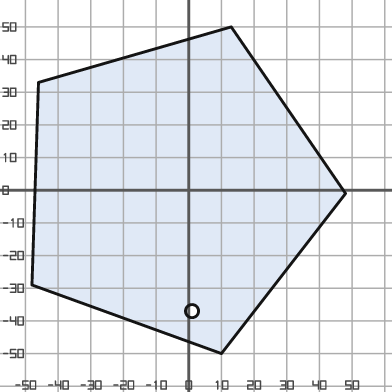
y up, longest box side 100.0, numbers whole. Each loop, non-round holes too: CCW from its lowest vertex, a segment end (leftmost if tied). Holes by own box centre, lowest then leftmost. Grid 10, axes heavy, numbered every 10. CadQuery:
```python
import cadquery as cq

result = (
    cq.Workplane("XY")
    .moveTo(10.0, -50.0)
    .lineTo(48.0, -1.0)
    .lineTo(13.0, 50.0)
    .lineTo(-46.0, 33.0)
    .lineTo(-48.0, -29.0)
    .close()
    .moveTo(1.0, -37.0)
    .circle(2.0)
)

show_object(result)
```